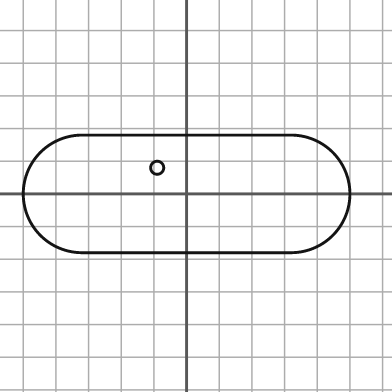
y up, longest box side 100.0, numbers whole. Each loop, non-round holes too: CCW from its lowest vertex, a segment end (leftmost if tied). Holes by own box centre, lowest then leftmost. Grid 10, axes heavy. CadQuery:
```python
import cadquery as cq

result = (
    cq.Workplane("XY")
    .moveTo(-32.0, -18.0)
    .lineTo(32.0, -18.0)
    .threePointArc((50.0, 0.0), (32.0, 18.0))
    .lineTo(-32.0, 18.0)
    .threePointArc((-50.0, 0.0), (-32.0, -18.0))
    .close()
    .moveTo(-9.0, 8.0)
    .circle(2.0)
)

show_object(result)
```